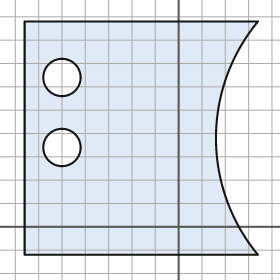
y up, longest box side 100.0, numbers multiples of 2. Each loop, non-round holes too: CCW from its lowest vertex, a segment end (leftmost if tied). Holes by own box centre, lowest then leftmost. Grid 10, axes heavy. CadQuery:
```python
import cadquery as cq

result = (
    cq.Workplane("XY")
    .moveTo(-66.0, -12.0)
    .lineTo(34.0, -12.0)
    .threePointArc((16.0, 38.0), (34.0, 88.0))
    .lineTo(-66.0, 88.0)
    .close()
    .moveTo(-50.0, 34.0)
    .circle(8.0)
    .moveTo(-50.0, 64.0)
    .circle(8.0)
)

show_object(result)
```